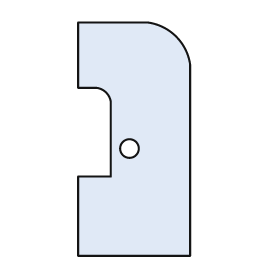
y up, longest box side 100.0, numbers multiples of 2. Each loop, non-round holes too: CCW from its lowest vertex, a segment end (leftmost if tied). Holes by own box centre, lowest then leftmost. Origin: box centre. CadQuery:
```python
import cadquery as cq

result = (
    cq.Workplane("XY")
    .moveTo(-24.0, -50.0)
    .lineTo(24.0, -50.0)
    .lineTo(24.0, 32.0)
    .threePointArc((18.0, 44.0), (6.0, 50.0))
    .lineTo(-24.0, 50.0)
    .lineTo(-24.0, 22.0)
    .lineTo(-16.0, 22.0)
    .threePointArc((-12.0, 20.0), (-10.0, 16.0))
    .lineTo(-10.0, -16.0)
    .lineTo(-24.0, -16.0)
    .close()
    .moveTo(-2.0, -4.0)
    .circle(4.0)
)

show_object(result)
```